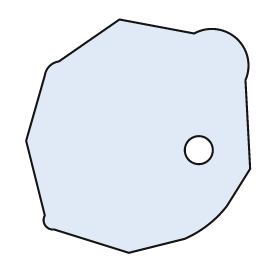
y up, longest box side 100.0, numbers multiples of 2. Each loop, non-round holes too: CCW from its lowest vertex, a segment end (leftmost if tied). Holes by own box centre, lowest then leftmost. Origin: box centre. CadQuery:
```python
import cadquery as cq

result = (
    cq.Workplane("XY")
    .moveTo(-4.0, -50.0)
    .lineTo(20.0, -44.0)
    .threePointArc((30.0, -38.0), (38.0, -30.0))
    .lineTo(48.0, -14.0)
    .lineTo(46.0, 24.0)
    .threePointArc((42.0, 42.0), (24.0, 44.0))
    .lineTo(-8.0, 50.0)
    .lineTo(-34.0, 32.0)
    .threePointArc((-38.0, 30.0), (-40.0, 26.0))
    .lineTo(-48.0, -2.0)
    .lineTo(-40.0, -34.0)
    .threePointArc((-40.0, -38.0), (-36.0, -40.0))
    .close()
    .moveTo(26.0, -6.0)
    .circle(6.0)
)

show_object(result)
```